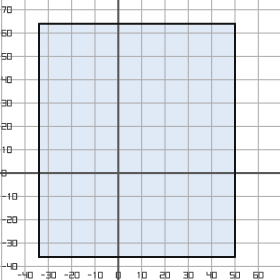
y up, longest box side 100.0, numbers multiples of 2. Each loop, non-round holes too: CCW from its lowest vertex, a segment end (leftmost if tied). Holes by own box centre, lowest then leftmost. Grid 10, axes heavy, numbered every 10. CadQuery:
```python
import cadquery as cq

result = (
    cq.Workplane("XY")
    .moveTo(-34.0, -36.0)
    .lineTo(50.0, -36.0)
    .lineTo(50.0, 64.0)
    .lineTo(-34.0, 64.0)
    .close()
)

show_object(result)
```